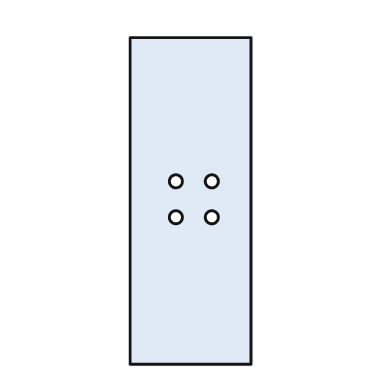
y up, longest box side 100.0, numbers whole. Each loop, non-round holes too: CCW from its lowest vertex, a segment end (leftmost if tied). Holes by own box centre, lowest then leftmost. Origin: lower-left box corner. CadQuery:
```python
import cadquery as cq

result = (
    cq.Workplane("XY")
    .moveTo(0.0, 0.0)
    .lineTo(37.0, 0.0)
    .lineTo(37.0, 100.0)
    .lineTo(0.0, 100.0)
    .close()
    .moveTo(14.0, 45.0)
    .circle(2.0)
    .moveTo(25.0, 45.0)
    .circle(2.0)
    .moveTo(14.0, 56.0)
    .circle(2.0)
    .moveTo(25.0, 56.0)
    .circle(2.0)
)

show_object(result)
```